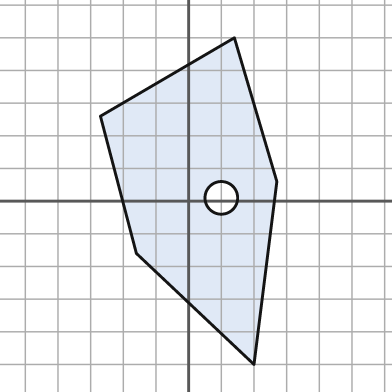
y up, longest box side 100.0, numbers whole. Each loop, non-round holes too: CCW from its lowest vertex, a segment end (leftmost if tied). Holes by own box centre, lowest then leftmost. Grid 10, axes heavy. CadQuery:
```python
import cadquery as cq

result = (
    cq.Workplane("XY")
    .moveTo(20.0, -50.0)
    .lineTo(27.0, 6.0)
    .lineTo(14.0, 50.0)
    .lineTo(-27.0, 26.0)
    .lineTo(-16.0, -16.0)
    .close()
    .moveTo(10.0, 1.0)
    .circle(5.0)
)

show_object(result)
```